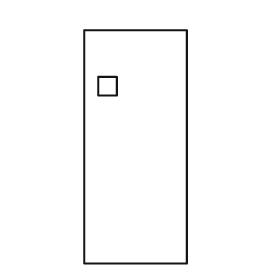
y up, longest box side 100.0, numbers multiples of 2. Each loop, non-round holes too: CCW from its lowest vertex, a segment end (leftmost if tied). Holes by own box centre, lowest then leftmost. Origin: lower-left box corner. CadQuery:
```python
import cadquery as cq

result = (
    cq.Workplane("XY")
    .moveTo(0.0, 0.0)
    .lineTo(44.0, 0.0)
    .lineTo(44.0, 100.0)
    .lineTo(0.0, 100.0)
    .close()
    .moveTo(6.0, 72.0)
    .lineTo(14.0, 72.0)
    .lineTo(14.0, 80.0)
    .lineTo(6.0, 80.0)
    .close()
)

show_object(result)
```